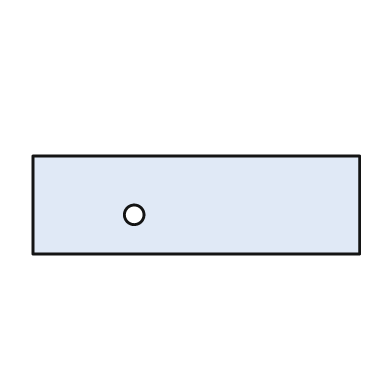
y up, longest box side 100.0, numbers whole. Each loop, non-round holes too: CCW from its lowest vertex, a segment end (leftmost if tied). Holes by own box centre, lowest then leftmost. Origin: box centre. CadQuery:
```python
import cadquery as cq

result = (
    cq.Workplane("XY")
    .moveTo(-50.0, -15.0)
    .lineTo(50.0, -15.0)
    .lineTo(50.0, 15.0)
    .lineTo(-50.0, 15.0)
    .close()
    .moveTo(-19.0, -3.0)
    .circle(3.0)
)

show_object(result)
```